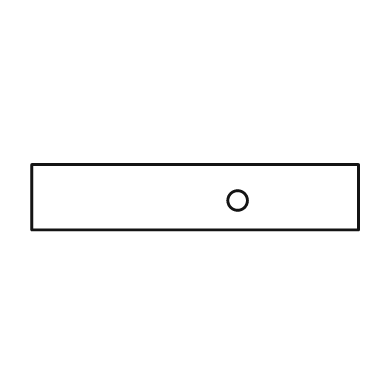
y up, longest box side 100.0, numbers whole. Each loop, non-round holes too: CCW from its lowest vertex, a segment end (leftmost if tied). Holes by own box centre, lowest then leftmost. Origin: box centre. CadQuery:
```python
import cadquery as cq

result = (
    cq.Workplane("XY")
    .moveTo(-50.0, -10.0)
    .lineTo(50.0, -10.0)
    .lineTo(50.0, 10.0)
    .lineTo(-50.0, 10.0)
    .close()
    .moveTo(13.0, -1.0)
    .circle(3.0)
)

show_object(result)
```